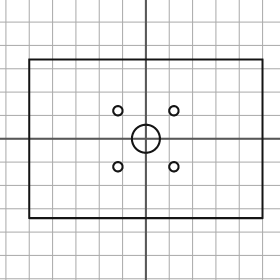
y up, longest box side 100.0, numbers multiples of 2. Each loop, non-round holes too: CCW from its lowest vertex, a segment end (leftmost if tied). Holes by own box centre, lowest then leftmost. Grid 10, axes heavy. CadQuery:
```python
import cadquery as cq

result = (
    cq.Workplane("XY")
    .moveTo(-50.0, -34.0)
    .lineTo(50.0, -34.0)
    .lineTo(50.0, 34.0)
    .lineTo(-50.0, 34.0)
    .close()
    .moveTo(-12.0, -12.0)
    .circle(2.0)
    .moveTo(12.0, -12.0)
    .circle(2.0)
    .moveTo(0.0, 0.0)
    .circle(6.0)
    .moveTo(-12.0, 12.0)
    .circle(2.0)
    .moveTo(12.0, 12.0)
    .circle(2.0)
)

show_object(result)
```